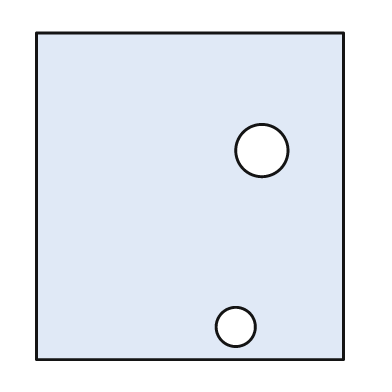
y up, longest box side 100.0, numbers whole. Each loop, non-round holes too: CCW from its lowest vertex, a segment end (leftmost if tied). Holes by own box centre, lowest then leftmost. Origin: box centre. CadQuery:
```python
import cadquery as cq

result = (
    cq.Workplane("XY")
    .moveTo(-47.0, -50.0)
    .lineTo(47.0, -50.0)
    .lineTo(47.0, 50.0)
    .lineTo(-47.0, 50.0)
    .close()
    .moveTo(14.0, -40.0)
    .circle(6.0)
    .moveTo(22.0, 14.0)
    .circle(8.0)
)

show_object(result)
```